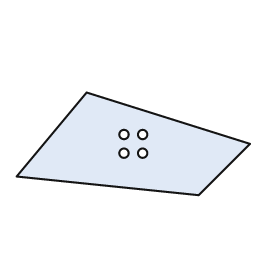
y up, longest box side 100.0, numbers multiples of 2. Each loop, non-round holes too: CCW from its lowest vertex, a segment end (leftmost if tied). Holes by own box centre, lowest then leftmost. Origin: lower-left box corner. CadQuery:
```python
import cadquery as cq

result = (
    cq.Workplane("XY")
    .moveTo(78.0, 0.0)
    .lineTo(100.0, 22.0)
    .lineTo(30.0, 44.0)
    .lineTo(0.0, 8.0)
    .close()
    .moveTo(46.0, 18.0)
    .circle(2.0)
    .moveTo(54.0, 18.0)
    .circle(2.0)
    .moveTo(46.0, 26.0)
    .circle(2.0)
    .moveTo(54.0, 26.0)
    .circle(2.0)
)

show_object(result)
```